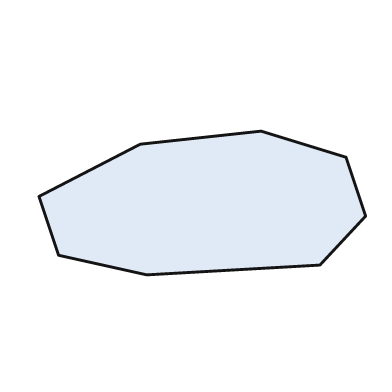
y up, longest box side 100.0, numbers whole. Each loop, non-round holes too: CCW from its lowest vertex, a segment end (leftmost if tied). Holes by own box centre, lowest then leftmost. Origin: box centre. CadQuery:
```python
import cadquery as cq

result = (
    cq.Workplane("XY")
    .moveTo(-17.0, -22.0)
    .lineTo(36.0, -19.0)
    .lineTo(50.0, -4.0)
    .lineTo(44.0, 14.0)
    .lineTo(18.0, 22.0)
    .lineTo(-19.0, 18.0)
    .lineTo(-50.0, 2.0)
    .lineTo(-44.0, -16.0)
    .close()
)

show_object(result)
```